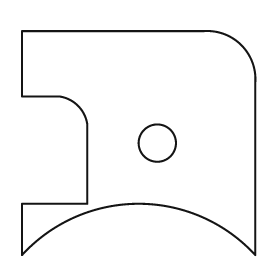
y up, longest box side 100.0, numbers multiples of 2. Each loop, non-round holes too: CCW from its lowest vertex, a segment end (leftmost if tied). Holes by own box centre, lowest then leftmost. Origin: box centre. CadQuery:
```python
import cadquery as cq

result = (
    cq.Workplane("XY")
    .moveTo(-50.0, -48.0)
    .threePointArc((0.0, -26.0), (50.0, -48.0))
    .lineTo(50.0, 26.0)
    .threePointArc((44.0, 42.0), (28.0, 48.0))
    .lineTo(-50.0, 48.0)
    .lineTo(-50.0, 20.0)
    .lineTo(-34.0, 20.0)
    .threePointArc((-26.0, 16.0), (-22.0, 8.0))
    .lineTo(-22.0, -26.0)
    .lineTo(-50.0, -26.0)
    .close()
    .moveTo(8.0, 0.0)
    .circle(8.0)
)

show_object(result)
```